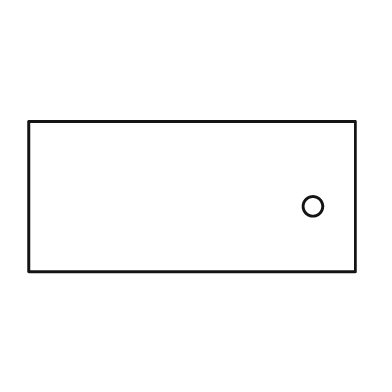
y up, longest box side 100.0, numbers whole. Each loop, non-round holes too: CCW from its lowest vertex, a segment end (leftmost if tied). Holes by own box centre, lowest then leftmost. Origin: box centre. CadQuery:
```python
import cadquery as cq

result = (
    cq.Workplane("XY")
    .moveTo(-50.0, -23.0)
    .lineTo(50.0, -23.0)
    .lineTo(50.0, 23.0)
    .lineTo(-50.0, 23.0)
    .close()
    .moveTo(37.0, -3.0)
    .circle(3.0)
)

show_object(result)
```